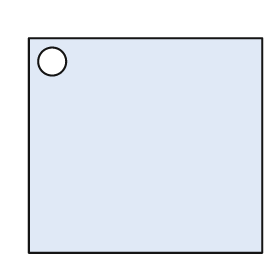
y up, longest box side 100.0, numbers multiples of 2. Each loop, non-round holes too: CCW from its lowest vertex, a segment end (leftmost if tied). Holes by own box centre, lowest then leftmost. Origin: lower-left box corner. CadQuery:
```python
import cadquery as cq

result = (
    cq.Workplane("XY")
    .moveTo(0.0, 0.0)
    .lineTo(100.0, 0.0)
    .lineTo(100.0, 92.0)
    .lineTo(0.0, 92.0)
    .close()
    .moveTo(10.0, 82.0)
    .circle(6.0)
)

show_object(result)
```